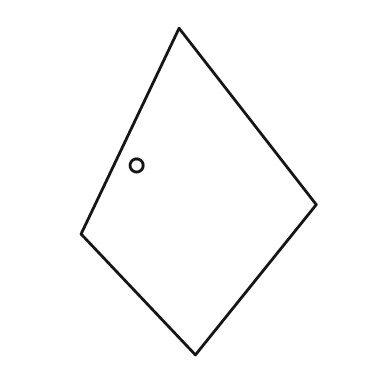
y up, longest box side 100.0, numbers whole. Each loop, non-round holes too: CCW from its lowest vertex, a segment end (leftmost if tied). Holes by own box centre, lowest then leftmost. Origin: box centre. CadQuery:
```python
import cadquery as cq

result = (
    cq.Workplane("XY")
    .moveTo(-1.0, -50.0)
    .lineTo(36.0, -4.0)
    .lineTo(-6.0, 50.0)
    .lineTo(-36.0, -13.0)
    .close()
    .moveTo(-19.0, 8.0)
    .circle(2.0)
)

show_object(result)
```